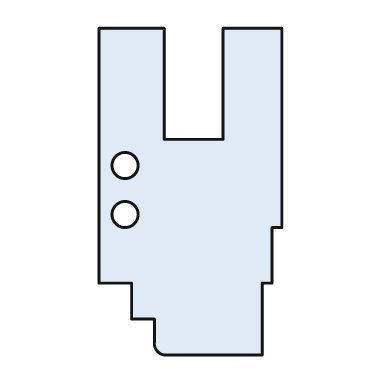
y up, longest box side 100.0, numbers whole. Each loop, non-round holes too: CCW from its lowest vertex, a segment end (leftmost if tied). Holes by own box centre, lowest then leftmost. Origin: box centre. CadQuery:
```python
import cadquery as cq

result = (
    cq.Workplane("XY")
    .moveTo(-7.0, -50.0)
    .lineTo(22.0, -50.0)
    .lineTo(22.0, -28.0)
    .lineTo(25.0, -28.0)
    .lineTo(25.0, -11.0)
    .lineTo(28.0, -11.0)
    .lineTo(28.0, 50.0)
    .lineTo(10.0, 50.0)
    .lineTo(10.0, 16.0)
    .lineTo(-8.0, 16.0)
    .lineTo(-8.0, 50.0)
    .lineTo(-28.0, 50.0)
    .lineTo(-28.0, -28.0)
    .lineTo(-18.0, -28.0)
    .lineTo(-18.0, -39.0)
    .lineTo(-11.0, -39.0)
    .lineTo(-11.0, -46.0)
    .threePointArc((-10.0, -49.0), (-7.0, -50.0))
    .close()
    .moveTo(-20.0, -7.0)
    .circle(4.0)
    .moveTo(-20.0, 8.0)
    .circle(4.0)
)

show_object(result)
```